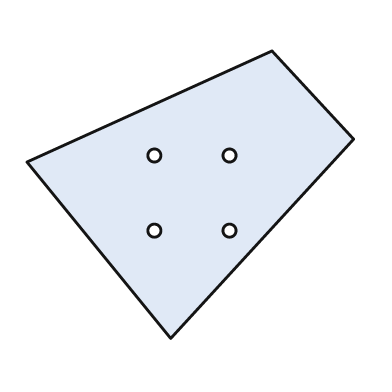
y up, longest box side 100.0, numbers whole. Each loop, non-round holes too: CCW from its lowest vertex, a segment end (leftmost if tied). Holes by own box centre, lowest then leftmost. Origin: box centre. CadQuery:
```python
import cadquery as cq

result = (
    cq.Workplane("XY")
    .moveTo(-6.0, -44.0)
    .lineTo(50.0, 17.0)
    .lineTo(25.0, 44.0)
    .lineTo(-50.0, 10.0)
    .close()
    .moveTo(-11.0, -11.0)
    .circle(2.0)
    .moveTo(12.0, -11.0)
    .circle(2.0)
    .moveTo(-11.0, 12.0)
    .circle(2.0)
    .moveTo(12.0, 12.0)
    .circle(2.0)
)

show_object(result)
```